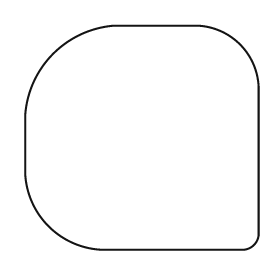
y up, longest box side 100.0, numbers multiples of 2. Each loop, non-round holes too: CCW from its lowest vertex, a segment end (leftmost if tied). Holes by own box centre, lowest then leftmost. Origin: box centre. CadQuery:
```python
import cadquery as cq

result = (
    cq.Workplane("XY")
    .moveTo(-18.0, -48.0)
    .lineTo(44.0, -48.0)
    .threePointArc((48.0, -46.0), (50.0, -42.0))
    .lineTo(50.0, 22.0)
    .threePointArc((42.0, 40.0), (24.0, 48.0))
    .lineTo(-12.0, 48.0)
    .threePointArc((-38.0, 36.0), (-50.0, 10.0))
    .lineTo(-50.0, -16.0)
    .threePointArc((-40.0, -38.0), (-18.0, -48.0))
    .close()
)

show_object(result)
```